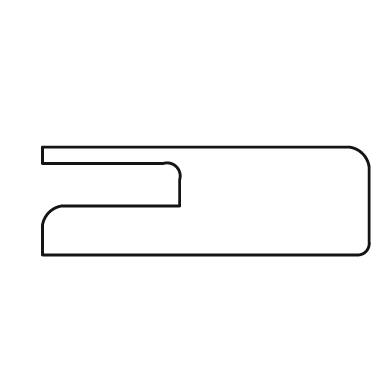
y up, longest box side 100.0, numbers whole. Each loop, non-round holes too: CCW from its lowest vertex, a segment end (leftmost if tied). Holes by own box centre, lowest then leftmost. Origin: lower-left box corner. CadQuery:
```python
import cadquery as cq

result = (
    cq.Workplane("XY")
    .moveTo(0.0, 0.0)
    .lineTo(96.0, 0.0)
    .threePointArc((99.0, 1.0), (100.0, 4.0))
    .lineTo(100.0, 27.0)
    .threePointArc((98.0, 31.0), (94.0, 33.0))
    .lineTo(0.0, 33.0)
    .lineTo(0.0, 28.0)
    .lineTo(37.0, 28.0)
    .threePointArc((41.0, 27.0), (42.0, 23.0))
    .lineTo(42.0, 15.0)
    .lineTo(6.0, 15.0)
    .threePointArc((2.0, 13.0), (0.0, 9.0))
    .close()
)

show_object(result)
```